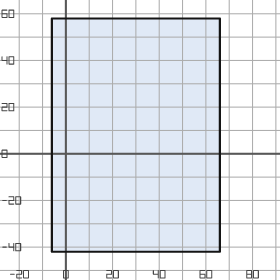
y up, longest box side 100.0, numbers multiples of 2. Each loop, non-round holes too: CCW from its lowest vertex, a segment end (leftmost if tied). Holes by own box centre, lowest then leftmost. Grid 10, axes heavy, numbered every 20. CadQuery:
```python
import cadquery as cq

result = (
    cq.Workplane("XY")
    .moveTo(-6.0, -42.0)
    .lineTo(66.0, -42.0)
    .lineTo(66.0, 58.0)
    .lineTo(-6.0, 58.0)
    .close()
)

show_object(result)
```